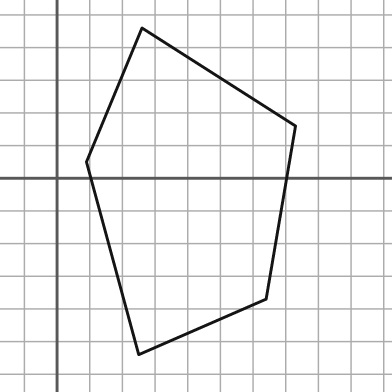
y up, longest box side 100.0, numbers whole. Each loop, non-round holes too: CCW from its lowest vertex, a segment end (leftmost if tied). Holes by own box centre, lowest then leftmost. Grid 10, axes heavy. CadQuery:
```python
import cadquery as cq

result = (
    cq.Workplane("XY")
    .moveTo(25.0, -54.0)
    .lineTo(64.0, -37.0)
    .lineTo(73.0, 16.0)
    .lineTo(26.0, 46.0)
    .lineTo(9.0, 5.0)
    .close()
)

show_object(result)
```